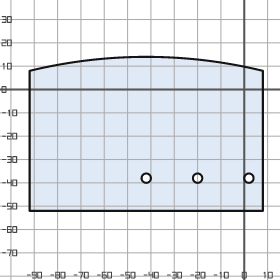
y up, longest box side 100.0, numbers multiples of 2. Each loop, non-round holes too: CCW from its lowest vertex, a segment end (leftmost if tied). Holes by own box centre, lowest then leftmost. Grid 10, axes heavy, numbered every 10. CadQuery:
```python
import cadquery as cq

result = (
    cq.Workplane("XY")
    .moveTo(-92.0, -52.0)
    .lineTo(8.0, -52.0)
    .lineTo(8.0, 8.0)
    .threePointArc((-42.0, 14.0), (-92.0, 8.0))
    .close()
    .moveTo(-42.0, -38.0)
    .circle(2.0)
    .moveTo(-20.0, -38.0)
    .circle(2.0)
    .moveTo(2.0, -38.0)
    .circle(2.0)
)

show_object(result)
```